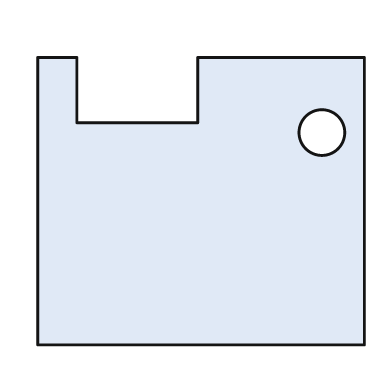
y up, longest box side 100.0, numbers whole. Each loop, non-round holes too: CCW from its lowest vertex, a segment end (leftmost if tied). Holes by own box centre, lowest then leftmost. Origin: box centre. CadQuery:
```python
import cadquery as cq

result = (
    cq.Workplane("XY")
    .moveTo(-50.0, -44.0)
    .lineTo(50.0, -44.0)
    .lineTo(50.0, 44.0)
    .lineTo(-1.0, 44.0)
    .lineTo(-1.0, 24.0)
    .lineTo(-38.0, 24.0)
    .lineTo(-38.0, 44.0)
    .lineTo(-50.0, 44.0)
    .close()
    .moveTo(37.0, 21.0)
    .circle(7.0)
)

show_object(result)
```